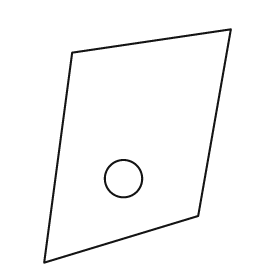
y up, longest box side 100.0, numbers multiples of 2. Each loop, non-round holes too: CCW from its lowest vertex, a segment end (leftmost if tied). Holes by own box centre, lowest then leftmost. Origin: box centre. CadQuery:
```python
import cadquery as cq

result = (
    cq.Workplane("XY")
    .moveTo(-40.0, -50.0)
    .lineTo(26.0, -30.0)
    .lineTo(40.0, 50.0)
    .lineTo(-28.0, 40.0)
    .close()
    .moveTo(-6.0, -14.0)
    .circle(8.0)
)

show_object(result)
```